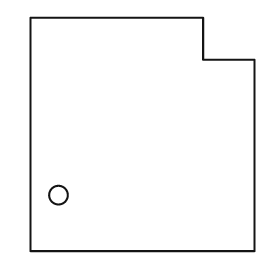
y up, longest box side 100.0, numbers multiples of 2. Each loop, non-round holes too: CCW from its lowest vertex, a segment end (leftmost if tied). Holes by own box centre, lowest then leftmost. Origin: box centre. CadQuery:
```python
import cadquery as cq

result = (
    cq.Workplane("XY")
    .moveTo(-48.0, -50.0)
    .lineTo(48.0, -50.0)
    .lineTo(48.0, 32.0)
    .lineTo(26.0, 32.0)
    .lineTo(26.0, 50.0)
    .lineTo(-48.0, 50.0)
    .close()
    .moveTo(-36.0, -26.0)
    .circle(4.0)
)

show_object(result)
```